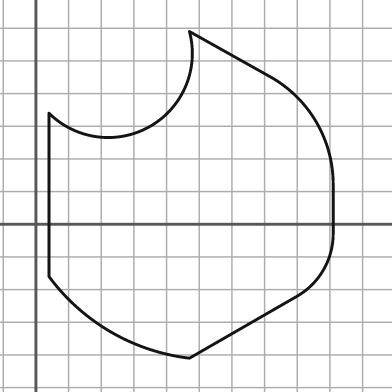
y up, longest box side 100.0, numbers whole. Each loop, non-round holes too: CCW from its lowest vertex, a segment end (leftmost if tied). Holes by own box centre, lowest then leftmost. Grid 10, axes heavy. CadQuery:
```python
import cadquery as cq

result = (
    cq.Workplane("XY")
    .moveTo(47.0, -41.0)
    .lineTo(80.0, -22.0)
    .threePointArc((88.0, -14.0), (91.0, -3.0))
    .lineTo(91.0, 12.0)
    .threePointArc((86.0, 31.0), (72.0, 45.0))
    .lineTo(47.0, 59.0)
    .threePointArc((35.0, 30.0), (4.0, 34.0))
    .lineTo(4.0, -16.0)
    .threePointArc((23.0, -33.0), (47.0, -41.0))
    .close()
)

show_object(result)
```